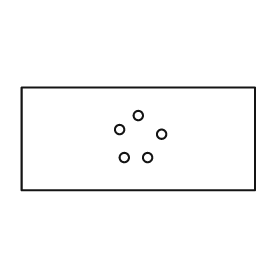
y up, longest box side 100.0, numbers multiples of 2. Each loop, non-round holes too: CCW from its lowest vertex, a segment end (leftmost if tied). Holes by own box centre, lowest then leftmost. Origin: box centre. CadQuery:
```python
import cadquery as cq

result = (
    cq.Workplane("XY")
    .moveTo(-50.0, -22.0)
    .lineTo(50.0, -22.0)
    .lineTo(50.0, 22.0)
    .lineTo(-50.0, 22.0)
    .close()
    .moveTo(-6.0, -8.0)
    .circle(2.0)
    .moveTo(4.0, -8.0)
    .circle(2.0)
    .moveTo(10.0, 2.0)
    .circle(2.0)
    .moveTo(-8.0, 4.0)
    .circle(2.0)
    .moveTo(0.0, 10.0)
    .circle(2.0)
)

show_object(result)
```